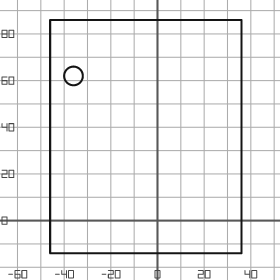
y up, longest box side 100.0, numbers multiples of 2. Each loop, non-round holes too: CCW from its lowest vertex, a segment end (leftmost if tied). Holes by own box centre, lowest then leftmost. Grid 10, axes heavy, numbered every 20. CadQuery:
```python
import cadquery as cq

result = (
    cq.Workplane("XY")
    .moveTo(-46.0, -14.0)
    .lineTo(36.0, -14.0)
    .lineTo(36.0, 86.0)
    .lineTo(-46.0, 86.0)
    .close()
    .moveTo(-36.0, 62.0)
    .circle(4.0)
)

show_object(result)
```